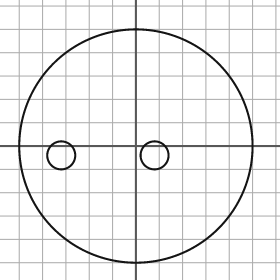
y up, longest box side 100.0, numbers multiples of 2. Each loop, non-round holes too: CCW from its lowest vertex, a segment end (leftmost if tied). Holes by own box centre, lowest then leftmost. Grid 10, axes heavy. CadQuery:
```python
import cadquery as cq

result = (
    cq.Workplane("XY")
    .moveTo(0.0, 0.0)
    .circle(50.0)
    .moveTo(-32.0, -4.0)
    .circle(6.0)
    .moveTo(8.0, -4.0)
    .circle(6.0)
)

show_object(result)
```